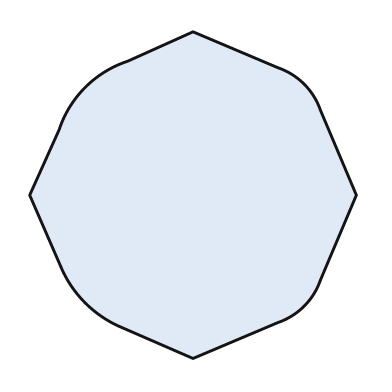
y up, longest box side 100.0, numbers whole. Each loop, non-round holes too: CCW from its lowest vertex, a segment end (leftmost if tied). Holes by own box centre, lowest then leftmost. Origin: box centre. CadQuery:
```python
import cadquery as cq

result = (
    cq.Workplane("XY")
    .moveTo(0.0, -50.0)
    .lineTo(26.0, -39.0)
    .threePointArc((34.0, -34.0), (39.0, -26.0))
    .lineTo(50.0, 0.0)
    .lineTo(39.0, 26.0)
    .threePointArc((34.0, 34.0), (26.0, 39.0))
    .lineTo(0.0, 50.0)
    .lineTo(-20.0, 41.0)
    .threePointArc((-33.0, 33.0), (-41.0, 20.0))
    .lineTo(-50.0, 0.0)
    .lineTo(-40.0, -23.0)
    .threePointArc((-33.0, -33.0), (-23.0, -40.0))
    .close()
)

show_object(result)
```